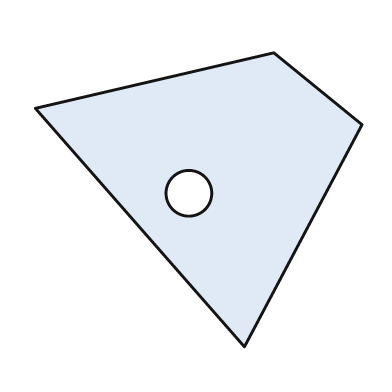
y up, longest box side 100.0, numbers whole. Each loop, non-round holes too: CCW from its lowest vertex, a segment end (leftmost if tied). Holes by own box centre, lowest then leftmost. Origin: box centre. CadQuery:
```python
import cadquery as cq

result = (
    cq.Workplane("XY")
    .moveTo(14.0, -45.0)
    .lineTo(50.0, 23.0)
    .lineTo(23.0, 45.0)
    .lineTo(-50.0, 28.0)
    .close()
    .moveTo(-3.0, 2.0)
    .circle(7.0)
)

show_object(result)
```